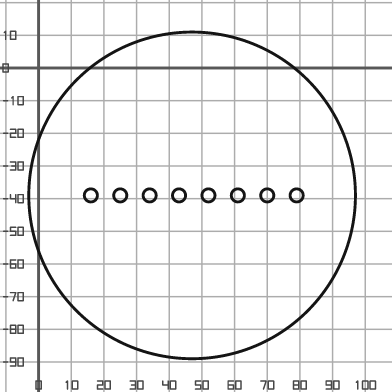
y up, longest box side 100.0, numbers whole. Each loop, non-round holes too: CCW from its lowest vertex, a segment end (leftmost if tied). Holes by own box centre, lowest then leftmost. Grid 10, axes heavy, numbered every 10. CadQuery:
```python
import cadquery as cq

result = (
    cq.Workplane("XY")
    .moveTo(47.0, -39.0)
    .circle(50.0)
    .moveTo(16.0, -39.0)
    .circle(2.0)
    .moveTo(25.0, -39.0)
    .circle(2.0)
    .moveTo(34.0, -39.0)
    .circle(2.0)
    .moveTo(43.0, -39.0)
    .circle(2.0)
    .moveTo(52.0, -39.0)
    .circle(2.0)
    .moveTo(61.0, -39.0)
    .circle(2.0)
    .moveTo(70.0, -39.0)
    .circle(2.0)
    .moveTo(79.0, -39.0)
    .circle(2.0)
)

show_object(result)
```